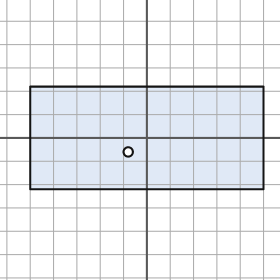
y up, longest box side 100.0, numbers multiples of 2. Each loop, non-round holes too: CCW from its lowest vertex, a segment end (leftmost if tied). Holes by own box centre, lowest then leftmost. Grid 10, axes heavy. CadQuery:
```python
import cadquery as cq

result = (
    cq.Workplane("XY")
    .moveTo(-50.0, -22.0)
    .lineTo(50.0, -22.0)
    .lineTo(50.0, 22.0)
    .lineTo(-50.0, 22.0)
    .close()
    .moveTo(-8.0, -6.0)
    .circle(2.0)
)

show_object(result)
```